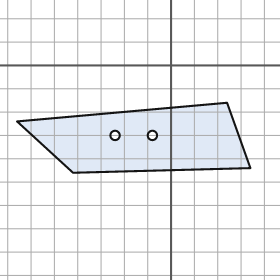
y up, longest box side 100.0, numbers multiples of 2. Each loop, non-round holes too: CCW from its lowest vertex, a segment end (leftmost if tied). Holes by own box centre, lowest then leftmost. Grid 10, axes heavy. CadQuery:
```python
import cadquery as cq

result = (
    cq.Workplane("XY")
    .moveTo(-42.0, -46.0)
    .lineTo(34.0, -44.0)
    .lineTo(24.0, -16.0)
    .lineTo(-66.0, -24.0)
    .close()
    .moveTo(-24.0, -30.0)
    .circle(2.0)
    .moveTo(-8.0, -30.0)
    .circle(2.0)
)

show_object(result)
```